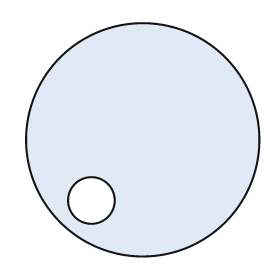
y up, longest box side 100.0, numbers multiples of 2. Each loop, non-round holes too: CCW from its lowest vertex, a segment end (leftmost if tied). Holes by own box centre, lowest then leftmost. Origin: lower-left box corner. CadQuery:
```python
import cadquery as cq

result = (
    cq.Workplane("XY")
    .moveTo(50.0, 50.0)
    .circle(50.0)
    .moveTo(28.0, 24.0)
    .circle(10.0)
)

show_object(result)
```